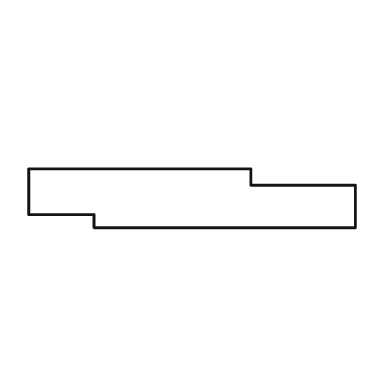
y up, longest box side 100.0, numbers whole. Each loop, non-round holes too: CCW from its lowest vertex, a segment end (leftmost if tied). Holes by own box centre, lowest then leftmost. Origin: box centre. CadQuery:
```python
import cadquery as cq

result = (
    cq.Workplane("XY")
    .moveTo(-30.0, -9.0)
    .lineTo(50.0, -9.0)
    .lineTo(50.0, 4.0)
    .lineTo(18.0, 4.0)
    .lineTo(18.0, 9.0)
    .lineTo(-50.0, 9.0)
    .lineTo(-50.0, -5.0)
    .lineTo(-30.0, -5.0)
    .close()
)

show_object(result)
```